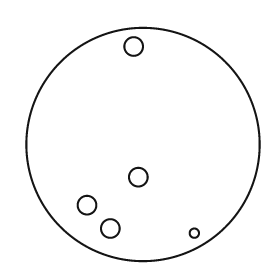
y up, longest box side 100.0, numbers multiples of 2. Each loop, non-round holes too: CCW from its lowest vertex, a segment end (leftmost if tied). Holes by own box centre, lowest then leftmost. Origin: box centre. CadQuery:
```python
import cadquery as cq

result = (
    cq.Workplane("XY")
    .moveTo(0.0, 0.0)
    .circle(50.0)
    .moveTo(22.0, -38.0)
    .circle(2.0)
    .moveTo(-14.0, -36.0)
    .circle(4.0)
    .moveTo(-24.0, -26.0)
    .circle(4.0)
    .moveTo(-2.0, -14.0)
    .circle(4.0)
    .moveTo(-4.0, 42.0)
    .circle(4.0)
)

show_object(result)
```